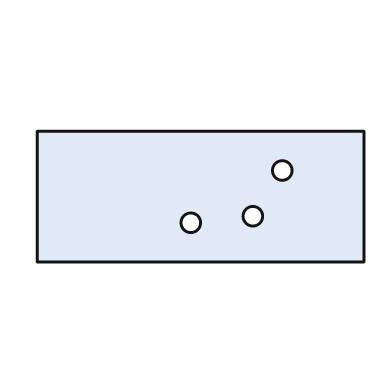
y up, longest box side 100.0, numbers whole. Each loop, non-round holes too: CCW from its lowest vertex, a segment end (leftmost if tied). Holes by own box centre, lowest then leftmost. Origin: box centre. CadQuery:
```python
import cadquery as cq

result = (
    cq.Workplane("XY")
    .moveTo(-50.0, -20.0)
    .lineTo(50.0, -20.0)
    .lineTo(50.0, 20.0)
    .lineTo(-50.0, 20.0)
    .close()
    .moveTo(-3.0, -8.0)
    .circle(3.0)
    .moveTo(16.0, -6.0)
    .circle(3.0)
    .moveTo(25.0, 8.0)
    .circle(3.0)
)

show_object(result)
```